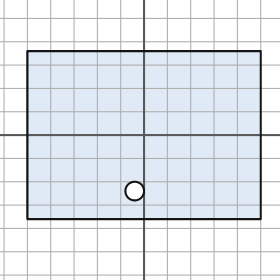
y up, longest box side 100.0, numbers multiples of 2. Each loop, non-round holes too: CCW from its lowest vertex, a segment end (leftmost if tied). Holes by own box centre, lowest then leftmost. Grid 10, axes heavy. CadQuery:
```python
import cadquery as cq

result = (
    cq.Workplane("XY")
    .moveTo(-50.0, -36.0)
    .lineTo(50.0, -36.0)
    .lineTo(50.0, 36.0)
    .lineTo(-50.0, 36.0)
    .close()
    .moveTo(-4.0, -24.0)
    .circle(4.0)
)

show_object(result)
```